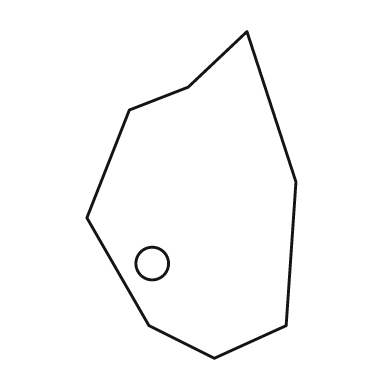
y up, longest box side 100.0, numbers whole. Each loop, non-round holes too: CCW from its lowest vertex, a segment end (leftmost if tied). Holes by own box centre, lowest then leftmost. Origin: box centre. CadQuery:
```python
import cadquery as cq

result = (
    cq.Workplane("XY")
    .moveTo(7.0, -50.0)
    .lineTo(29.0, -40.0)
    .lineTo(32.0, 4.0)
    .lineTo(17.0, 50.0)
    .lineTo(-1.0, 33.0)
    .lineTo(-19.0, 26.0)
    .lineTo(-32.0, -7.0)
    .lineTo(-13.0, -40.0)
    .close()
    .moveTo(-12.0, -21.0)
    .circle(5.0)
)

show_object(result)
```